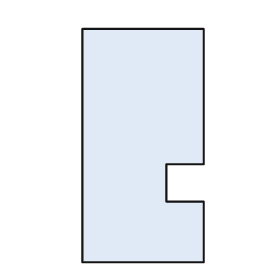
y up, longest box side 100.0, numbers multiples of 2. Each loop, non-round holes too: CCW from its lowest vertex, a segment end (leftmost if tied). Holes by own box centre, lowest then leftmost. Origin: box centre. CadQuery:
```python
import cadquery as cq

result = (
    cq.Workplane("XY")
    .moveTo(-26.0, -50.0)
    .lineTo(26.0, -50.0)
    .lineTo(26.0, -24.0)
    .lineTo(10.0, -24.0)
    .lineTo(10.0, -8.0)
    .lineTo(26.0, -8.0)
    .lineTo(26.0, 50.0)
    .lineTo(-26.0, 50.0)
    .close()
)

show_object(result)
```